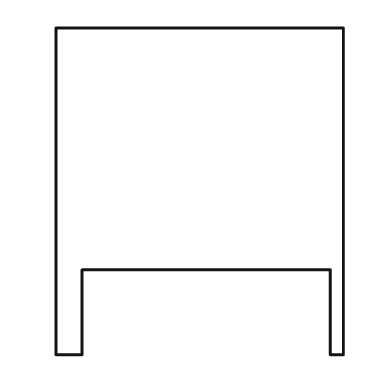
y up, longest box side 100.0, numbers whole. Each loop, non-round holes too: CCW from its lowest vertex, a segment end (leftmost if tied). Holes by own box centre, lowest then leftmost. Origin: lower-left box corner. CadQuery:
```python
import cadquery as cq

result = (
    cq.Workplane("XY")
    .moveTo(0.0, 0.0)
    .lineTo(8.0, 0.0)
    .lineTo(8.0, 26.0)
    .lineTo(84.0, 26.0)
    .lineTo(84.0, 0.0)
    .lineTo(88.0, 0.0)
    .lineTo(88.0, 100.0)
    .lineTo(0.0, 100.0)
    .close()
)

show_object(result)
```